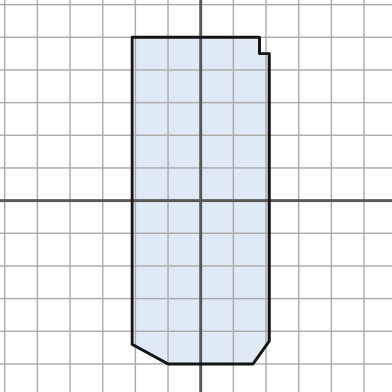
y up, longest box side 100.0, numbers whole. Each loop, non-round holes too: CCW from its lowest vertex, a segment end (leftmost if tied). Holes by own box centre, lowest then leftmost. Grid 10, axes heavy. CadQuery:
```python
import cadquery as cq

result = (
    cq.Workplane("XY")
    .moveTo(-10.0, -50.0)
    .lineTo(16.0, -50.0)
    .lineTo(21.0, -43.0)
    .lineTo(21.0, 45.0)
    .lineTo(18.0, 45.0)
    .lineTo(18.0, 50.0)
    .lineTo(-21.0, 50.0)
    .lineTo(-21.0, -44.0)
    .close()
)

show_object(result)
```